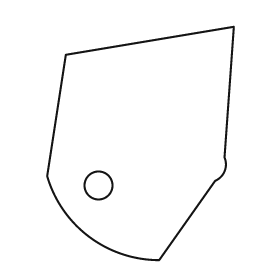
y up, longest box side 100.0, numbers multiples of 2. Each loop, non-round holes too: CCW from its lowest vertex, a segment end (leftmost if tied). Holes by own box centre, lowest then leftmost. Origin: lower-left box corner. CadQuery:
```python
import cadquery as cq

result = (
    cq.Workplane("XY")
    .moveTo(48.0, 0.0)
    .lineTo(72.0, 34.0)
    .threePointArc((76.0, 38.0), (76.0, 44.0))
    .lineTo(80.0, 100.0)
    .lineTo(8.0, 88.0)
    .lineTo(0.0, 36.0)
    .threePointArc((18.0, 10.0), (48.0, 0.0))
    .close()
    .moveTo(22.0, 32.0)
    .circle(6.0)
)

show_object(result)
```